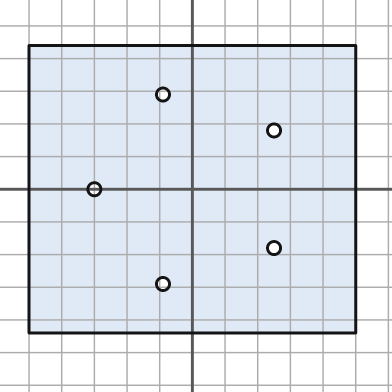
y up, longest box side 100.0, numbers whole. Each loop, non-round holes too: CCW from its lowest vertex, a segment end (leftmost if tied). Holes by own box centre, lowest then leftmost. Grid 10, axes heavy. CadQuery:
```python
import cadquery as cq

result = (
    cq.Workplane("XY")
    .moveTo(-50.0, -44.0)
    .lineTo(50.0, -44.0)
    .lineTo(50.0, 44.0)
    .lineTo(-50.0, 44.0)
    .close()
    .moveTo(-9.0, -29.0)
    .circle(2.0)
    .moveTo(25.0, -18.0)
    .circle(2.0)
    .moveTo(-30.0, 0.0)
    .circle(2.0)
    .moveTo(25.0, 18.0)
    .circle(2.0)
    .moveTo(-9.0, 29.0)
    .circle(2.0)
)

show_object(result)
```